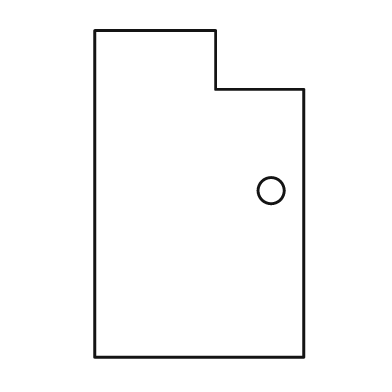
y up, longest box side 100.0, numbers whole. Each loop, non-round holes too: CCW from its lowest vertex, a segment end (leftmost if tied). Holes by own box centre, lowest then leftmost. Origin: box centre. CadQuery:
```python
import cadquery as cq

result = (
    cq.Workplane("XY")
    .moveTo(-32.0, -50.0)
    .lineTo(32.0, -50.0)
    .lineTo(32.0, 32.0)
    .lineTo(5.0, 32.0)
    .lineTo(5.0, 50.0)
    .lineTo(-32.0, 50.0)
    .close()
    .moveTo(22.0, 1.0)
    .circle(4.0)
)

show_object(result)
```